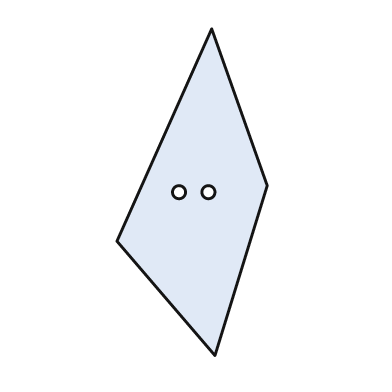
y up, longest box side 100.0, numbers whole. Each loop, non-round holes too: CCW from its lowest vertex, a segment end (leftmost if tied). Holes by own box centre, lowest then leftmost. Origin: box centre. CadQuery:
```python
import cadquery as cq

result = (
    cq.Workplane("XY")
    .moveTo(7.0, -50.0)
    .lineTo(23.0, 2.0)
    .lineTo(6.0, 50.0)
    .lineTo(-23.0, -15.0)
    .close()
    .moveTo(-4.0, 0.0)
    .circle(2.0)
    .moveTo(5.0, 0.0)
    .circle(2.0)
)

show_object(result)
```